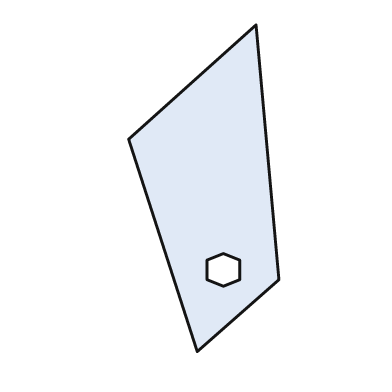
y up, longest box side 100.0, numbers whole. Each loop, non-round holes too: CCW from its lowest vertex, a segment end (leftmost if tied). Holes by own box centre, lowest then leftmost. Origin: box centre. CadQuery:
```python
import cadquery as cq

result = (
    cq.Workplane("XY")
    .moveTo(-2.0, -50.0)
    .lineTo(23.0, -28.0)
    .lineTo(16.0, 50.0)
    .lineTo(-23.0, 15.0)
    .close()
    .moveTo(6.0, -30.0)
    .lineTo(11.0, -28.0)
    .lineTo(11.0, -22.0)
    .lineTo(6.0, -20.0)
    .lineTo(1.0, -22.0)
    .lineTo(1.0, -28.0)
    .close()
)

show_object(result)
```